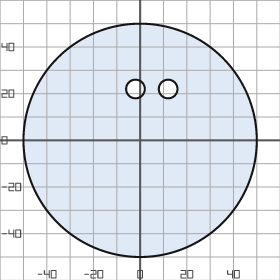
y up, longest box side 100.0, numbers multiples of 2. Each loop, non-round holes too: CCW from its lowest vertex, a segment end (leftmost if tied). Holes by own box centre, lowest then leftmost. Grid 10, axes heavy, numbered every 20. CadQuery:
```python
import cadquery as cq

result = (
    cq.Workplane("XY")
    .moveTo(0.0, 0.0)
    .circle(50.0)
    .moveTo(-2.0, 22.0)
    .circle(4.0)
    .moveTo(12.0, 22.0)
    .circle(4.0)
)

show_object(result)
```